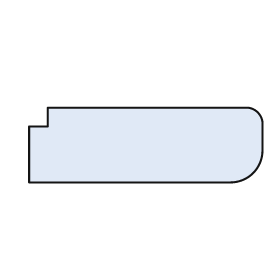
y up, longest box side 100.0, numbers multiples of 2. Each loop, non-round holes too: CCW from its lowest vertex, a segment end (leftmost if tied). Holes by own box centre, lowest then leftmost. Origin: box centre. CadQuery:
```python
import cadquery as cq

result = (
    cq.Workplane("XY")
    .moveTo(-50.0, -16.0)
    .lineTo(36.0, -16.0)
    .threePointArc((46.0, -12.0), (50.0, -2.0))
    .lineTo(50.0, 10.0)
    .threePointArc((48.0, 14.0), (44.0, 16.0))
    .lineTo(-42.0, 16.0)
    .lineTo(-42.0, 8.0)
    .lineTo(-50.0, 8.0)
    .close()
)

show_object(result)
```